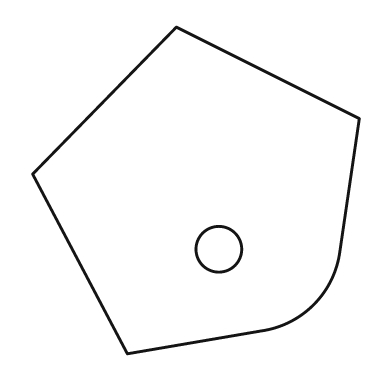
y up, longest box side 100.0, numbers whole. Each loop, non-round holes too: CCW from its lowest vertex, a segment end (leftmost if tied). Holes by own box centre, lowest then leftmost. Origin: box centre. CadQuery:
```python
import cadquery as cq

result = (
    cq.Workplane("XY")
    .moveTo(-21.0, -50.0)
    .lineTo(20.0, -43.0)
    .threePointArc((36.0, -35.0), (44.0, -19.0))
    .lineTo(50.0, 22.0)
    .lineTo(-6.0, 50.0)
    .lineTo(-50.0, 5.0)
    .close()
    .moveTo(7.0, -18.0)
    .circle(7.0)
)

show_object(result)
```